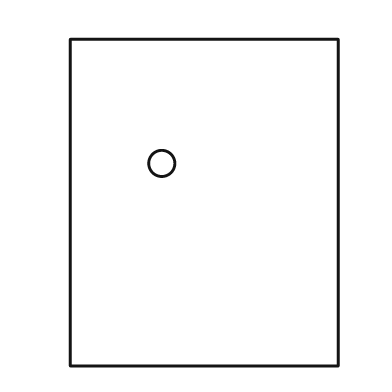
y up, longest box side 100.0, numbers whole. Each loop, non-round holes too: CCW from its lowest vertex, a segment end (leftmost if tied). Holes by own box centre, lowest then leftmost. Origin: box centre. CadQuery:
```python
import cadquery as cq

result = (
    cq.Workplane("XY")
    .moveTo(-41.0, -50.0)
    .lineTo(41.0, -50.0)
    .lineTo(41.0, 50.0)
    .lineTo(-41.0, 50.0)
    .close()
    .moveTo(-13.0, 12.0)
    .circle(4.0)
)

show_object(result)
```